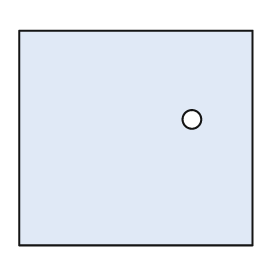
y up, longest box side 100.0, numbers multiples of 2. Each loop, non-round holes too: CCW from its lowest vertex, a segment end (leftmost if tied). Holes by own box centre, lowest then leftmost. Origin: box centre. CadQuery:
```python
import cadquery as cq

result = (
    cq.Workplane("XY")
    .moveTo(-50.0, -46.0)
    .lineTo(50.0, -46.0)
    .lineTo(50.0, 46.0)
    .lineTo(-50.0, 46.0)
    .close()
    .moveTo(24.0, 8.0)
    .circle(4.0)
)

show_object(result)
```